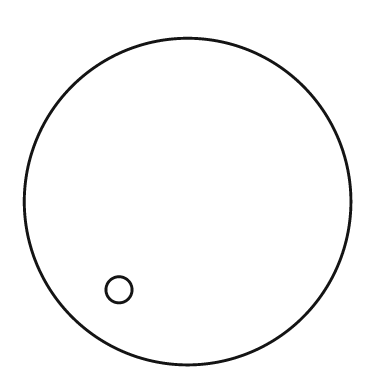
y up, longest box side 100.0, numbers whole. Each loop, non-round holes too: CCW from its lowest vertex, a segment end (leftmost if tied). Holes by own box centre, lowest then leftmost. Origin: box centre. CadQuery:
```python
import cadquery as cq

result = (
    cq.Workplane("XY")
    .moveTo(0.0, 0.0)
    .circle(50.0)
    .moveTo(-21.0, -27.0)
    .circle(4.0)
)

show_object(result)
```